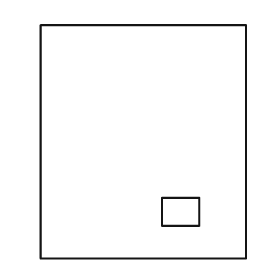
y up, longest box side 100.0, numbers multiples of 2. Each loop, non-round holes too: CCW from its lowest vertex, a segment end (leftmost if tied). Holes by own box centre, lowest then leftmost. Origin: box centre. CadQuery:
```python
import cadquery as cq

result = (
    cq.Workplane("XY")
    .moveTo(-44.0, -50.0)
    .lineTo(44.0, -50.0)
    .lineTo(44.0, 50.0)
    .lineTo(-44.0, 50.0)
    .close()
    .moveTo(8.0, -36.0)
    .lineTo(24.0, -36.0)
    .lineTo(24.0, -24.0)
    .lineTo(8.0, -24.0)
    .close()
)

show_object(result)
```